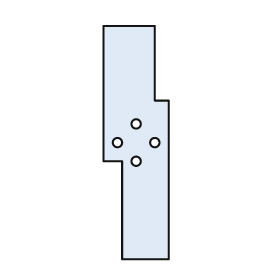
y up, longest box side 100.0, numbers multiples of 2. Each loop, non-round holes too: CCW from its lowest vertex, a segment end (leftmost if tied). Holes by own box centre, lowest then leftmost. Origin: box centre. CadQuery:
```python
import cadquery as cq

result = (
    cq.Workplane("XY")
    .moveTo(-6.0, -50.0)
    .lineTo(14.0, -50.0)
    .lineTo(14.0, 18.0)
    .lineTo(8.0, 18.0)
    .lineTo(8.0, 50.0)
    .lineTo(-14.0, 50.0)
    .lineTo(-14.0, -8.0)
    .lineTo(-6.0, -8.0)
    .close()
    .moveTo(0.0, -8.0)
    .circle(2.0)
    .moveTo(-8.0, 0.0)
    .circle(2.0)
    .moveTo(8.0, 0.0)
    .circle(2.0)
    .moveTo(0.0, 8.0)
    .circle(2.0)
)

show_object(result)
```